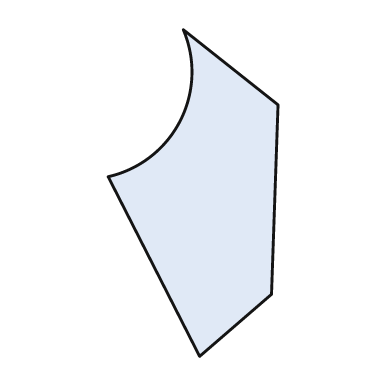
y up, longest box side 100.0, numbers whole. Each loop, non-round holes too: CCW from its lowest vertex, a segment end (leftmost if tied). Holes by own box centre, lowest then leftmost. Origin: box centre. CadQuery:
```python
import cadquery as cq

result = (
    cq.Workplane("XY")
    .moveTo(2.0, -50.0)
    .lineTo(24.0, -31.0)
    .lineTo(26.0, 27.0)
    .lineTo(-3.0, 50.0)
    .threePointArc((-4.0, 22.0), (-26.0, 5.0))
    .close()
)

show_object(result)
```